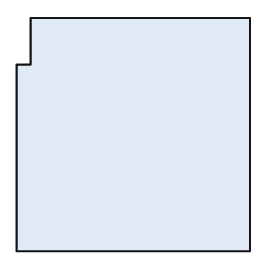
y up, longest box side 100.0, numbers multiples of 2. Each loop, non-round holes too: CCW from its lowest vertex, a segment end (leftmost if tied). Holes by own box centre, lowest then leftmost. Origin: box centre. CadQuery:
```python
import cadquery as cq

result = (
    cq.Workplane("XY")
    .moveTo(-50.0, -50.0)
    .lineTo(50.0, -50.0)
    .lineTo(50.0, 50.0)
    .lineTo(-44.0, 50.0)
    .lineTo(-44.0, 30.0)
    .lineTo(-50.0, 30.0)
    .close()
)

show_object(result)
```